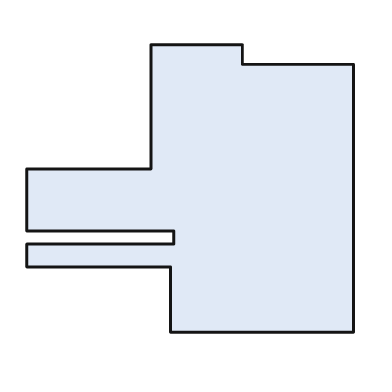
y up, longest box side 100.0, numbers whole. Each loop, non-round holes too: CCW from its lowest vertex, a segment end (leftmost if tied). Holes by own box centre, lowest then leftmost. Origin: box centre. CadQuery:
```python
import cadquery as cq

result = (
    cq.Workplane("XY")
    .moveTo(-6.0, -44.0)
    .lineTo(50.0, -44.0)
    .lineTo(50.0, 38.0)
    .lineTo(16.0, 38.0)
    .lineTo(16.0, 44.0)
    .lineTo(-12.0, 44.0)
    .lineTo(-12.0, 6.0)
    .lineTo(-50.0, 6.0)
    .lineTo(-50.0, -13.0)
    .lineTo(-5.0, -13.0)
    .lineTo(-5.0, -17.0)
    .lineTo(-50.0, -17.0)
    .lineTo(-50.0, -24.0)
    .lineTo(-6.0, -24.0)
    .close()
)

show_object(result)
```